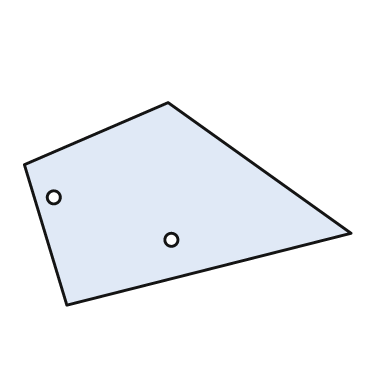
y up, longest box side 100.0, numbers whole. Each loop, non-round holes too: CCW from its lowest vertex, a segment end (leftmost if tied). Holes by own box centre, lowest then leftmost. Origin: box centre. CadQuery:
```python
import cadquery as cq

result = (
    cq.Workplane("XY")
    .moveTo(-37.0, -31.0)
    .lineTo(50.0, -9.0)
    .lineTo(-6.0, 31.0)
    .lineTo(-50.0, 12.0)
    .close()
    .moveTo(-5.0, -11.0)
    .circle(2.0)
    .moveTo(-41.0, 2.0)
    .circle(2.0)
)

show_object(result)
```